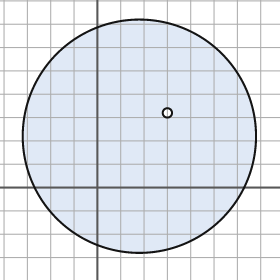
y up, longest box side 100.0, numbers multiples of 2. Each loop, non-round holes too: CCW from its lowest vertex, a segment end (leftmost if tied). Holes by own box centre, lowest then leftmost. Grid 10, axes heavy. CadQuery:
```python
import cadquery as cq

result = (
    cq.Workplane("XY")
    .moveTo(18.0, 22.0)
    .circle(50.0)
    .moveTo(30.0, 32.0)
    .circle(2.0)
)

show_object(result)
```